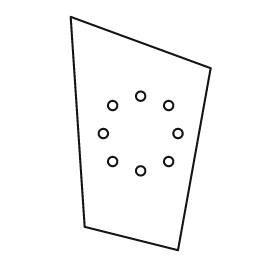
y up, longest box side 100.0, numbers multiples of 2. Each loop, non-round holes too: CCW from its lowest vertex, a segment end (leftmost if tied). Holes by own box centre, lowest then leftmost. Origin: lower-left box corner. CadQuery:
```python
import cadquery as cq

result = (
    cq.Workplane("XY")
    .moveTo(46.0, 0.0)
    .lineTo(60.0, 78.0)
    .lineTo(0.0, 100.0)
    .lineTo(6.0, 10.0)
    .close()
    .moveTo(30.0, 34.0)
    .circle(2.0)
    .moveTo(18.0, 38.0)
    .circle(2.0)
    .moveTo(42.0, 38.0)
    .circle(2.0)
    .moveTo(14.0, 50.0)
    .circle(2.0)
    .moveTo(46.0, 50.0)
    .circle(2.0)
    .moveTo(18.0, 62.0)
    .circle(2.0)
    .moveTo(42.0, 62.0)
    .circle(2.0)
    .moveTo(30.0, 66.0)
    .circle(2.0)
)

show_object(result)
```